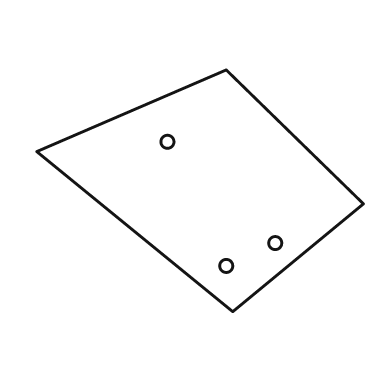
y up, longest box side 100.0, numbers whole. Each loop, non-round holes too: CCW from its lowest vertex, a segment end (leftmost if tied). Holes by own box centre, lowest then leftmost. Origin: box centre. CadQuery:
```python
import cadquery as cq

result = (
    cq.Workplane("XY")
    .moveTo(10.0, -37.0)
    .lineTo(50.0, -4.0)
    .lineTo(8.0, 37.0)
    .lineTo(-50.0, 12.0)
    .close()
    .moveTo(8.0, -23.0)
    .circle(2.0)
    .moveTo(23.0, -16.0)
    .circle(2.0)
    .moveTo(-10.0, 15.0)
    .circle(2.0)
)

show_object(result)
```